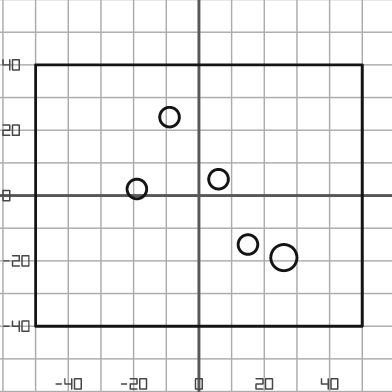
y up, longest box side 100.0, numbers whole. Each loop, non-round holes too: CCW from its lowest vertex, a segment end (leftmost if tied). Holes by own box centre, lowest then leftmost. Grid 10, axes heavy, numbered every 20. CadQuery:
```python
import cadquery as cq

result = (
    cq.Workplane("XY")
    .moveTo(-50.0, -40.0)
    .lineTo(50.0, -40.0)
    .lineTo(50.0, 40.0)
    .lineTo(-50.0, 40.0)
    .close()
    .moveTo(26.0, -19.0)
    .circle(4.0)
    .moveTo(15.0, -15.0)
    .circle(3.0)
    .moveTo(-19.0, 2.0)
    .circle(3.0)
    .moveTo(6.0, 5.0)
    .circle(3.0)
    .moveTo(-9.0, 24.0)
    .circle(3.0)
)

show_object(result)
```